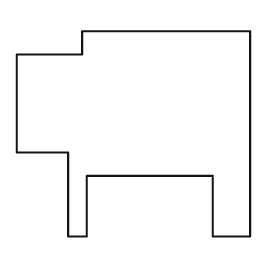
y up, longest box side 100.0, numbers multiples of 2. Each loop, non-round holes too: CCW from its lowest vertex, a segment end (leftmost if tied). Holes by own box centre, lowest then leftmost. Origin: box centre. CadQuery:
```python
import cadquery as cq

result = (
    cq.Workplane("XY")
    .moveTo(-28.0, -44.0)
    .lineTo(-20.0, -44.0)
    .lineTo(-20.0, -18.0)
    .lineTo(34.0, -18.0)
    .lineTo(34.0, -44.0)
    .lineTo(50.0, -44.0)
    .lineTo(50.0, 44.0)
    .lineTo(-22.0, 44.0)
    .lineTo(-22.0, 34.0)
    .lineTo(-50.0, 34.0)
    .lineTo(-50.0, -8.0)
    .lineTo(-28.0, -8.0)
    .close()
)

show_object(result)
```